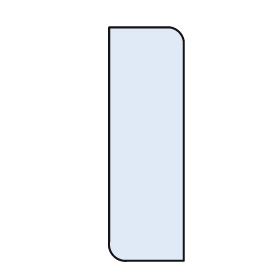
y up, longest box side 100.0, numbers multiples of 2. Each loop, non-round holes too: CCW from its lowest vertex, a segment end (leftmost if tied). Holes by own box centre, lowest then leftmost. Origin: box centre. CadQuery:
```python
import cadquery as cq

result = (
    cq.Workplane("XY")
    .moveTo(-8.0, -50.0)
    .lineTo(16.0, -50.0)
    .lineTo(16.0, 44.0)
    .threePointArc((14.0, 48.0), (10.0, 50.0))
    .lineTo(-16.0, 50.0)
    .lineTo(-16.0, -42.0)
    .threePointArc((-14.0, -48.0), (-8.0, -50.0))
    .close()
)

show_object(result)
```